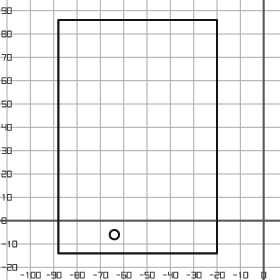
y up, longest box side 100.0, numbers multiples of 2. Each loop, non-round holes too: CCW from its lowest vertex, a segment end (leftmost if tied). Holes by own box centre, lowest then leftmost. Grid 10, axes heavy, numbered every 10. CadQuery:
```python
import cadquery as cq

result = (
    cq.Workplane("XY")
    .moveTo(-88.0, -14.0)
    .lineTo(-20.0, -14.0)
    .lineTo(-20.0, 86.0)
    .lineTo(-88.0, 86.0)
    .close()
    .moveTo(-64.0, -6.0)
    .circle(2.0)
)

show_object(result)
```